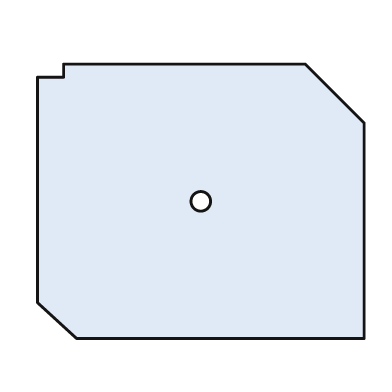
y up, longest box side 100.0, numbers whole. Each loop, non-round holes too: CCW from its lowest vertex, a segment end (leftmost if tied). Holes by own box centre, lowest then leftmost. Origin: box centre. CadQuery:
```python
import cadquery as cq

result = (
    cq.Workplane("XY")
    .moveTo(-38.0, -42.0)
    .lineTo(50.0, -42.0)
    .lineTo(50.0, 24.0)
    .lineTo(32.0, 42.0)
    .lineTo(-42.0, 42.0)
    .lineTo(-42.0, 38.0)
    .lineTo(-50.0, 38.0)
    .lineTo(-50.0, -31.0)
    .close()
    .moveTo(0.0, 0.0)
    .circle(3.0)
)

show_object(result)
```